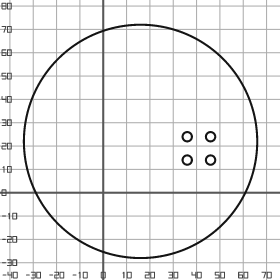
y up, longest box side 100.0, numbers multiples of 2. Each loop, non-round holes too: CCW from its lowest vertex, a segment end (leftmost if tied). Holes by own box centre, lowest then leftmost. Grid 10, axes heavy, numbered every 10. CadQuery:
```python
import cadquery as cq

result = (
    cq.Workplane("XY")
    .moveTo(16.0, 22.0)
    .circle(50.0)
    .moveTo(36.0, 14.0)
    .circle(2.0)
    .moveTo(46.0, 14.0)
    .circle(2.0)
    .moveTo(36.0, 24.0)
    .circle(2.0)
    .moveTo(46.0, 24.0)
    .circle(2.0)
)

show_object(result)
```